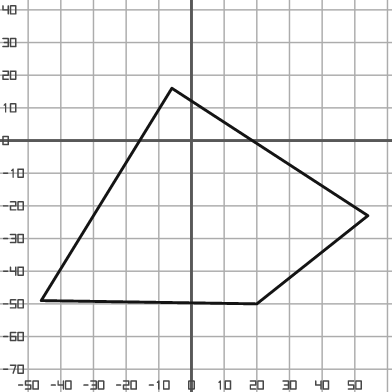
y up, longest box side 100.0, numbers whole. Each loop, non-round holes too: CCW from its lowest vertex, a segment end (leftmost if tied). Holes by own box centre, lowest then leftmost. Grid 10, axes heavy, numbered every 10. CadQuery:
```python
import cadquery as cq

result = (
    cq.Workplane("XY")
    .moveTo(20.0, -50.0)
    .lineTo(54.0, -23.0)
    .lineTo(-6.0, 16.0)
    .lineTo(-46.0, -49.0)
    .close()
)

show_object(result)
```